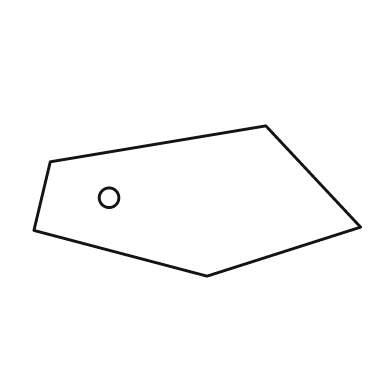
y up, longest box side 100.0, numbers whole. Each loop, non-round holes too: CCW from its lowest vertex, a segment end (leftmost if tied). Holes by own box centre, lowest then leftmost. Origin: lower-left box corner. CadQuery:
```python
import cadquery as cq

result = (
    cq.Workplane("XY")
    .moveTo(53.0, 0.0)
    .lineTo(100.0, 15.0)
    .lineTo(71.0, 46.0)
    .lineTo(5.0, 35.0)
    .lineTo(0.0, 14.0)
    .close()
    .moveTo(23.0, 24.0)
    .circle(3.0)
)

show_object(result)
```